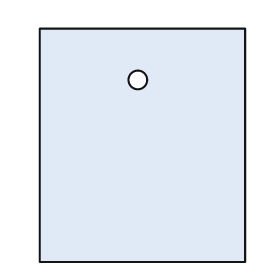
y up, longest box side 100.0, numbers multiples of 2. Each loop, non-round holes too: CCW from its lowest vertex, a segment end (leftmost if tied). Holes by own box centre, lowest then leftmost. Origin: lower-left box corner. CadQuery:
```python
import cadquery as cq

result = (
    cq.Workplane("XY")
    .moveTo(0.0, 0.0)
    .lineTo(88.0, 0.0)
    .lineTo(88.0, 100.0)
    .lineTo(0.0, 100.0)
    .close()
    .moveTo(42.0, 78.0)
    .circle(4.0)
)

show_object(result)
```